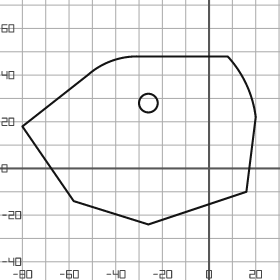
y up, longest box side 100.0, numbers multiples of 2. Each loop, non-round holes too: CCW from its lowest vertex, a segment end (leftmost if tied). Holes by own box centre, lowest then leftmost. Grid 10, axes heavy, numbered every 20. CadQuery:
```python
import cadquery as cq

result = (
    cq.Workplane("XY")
    .moveTo(-26.0, -24.0)
    .lineTo(16.0, -10.0)
    .lineTo(20.0, 22.0)
    .threePointArc((16.0, 36.0), (8.0, 48.0))
    .lineTo(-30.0, 48.0)
    .threePointArc((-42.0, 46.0), (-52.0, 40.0))
    .lineTo(-80.0, 18.0)
    .lineTo(-58.0, -14.0)
    .close()
    .moveTo(-26.0, 28.0)
    .circle(4.0)
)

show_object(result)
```